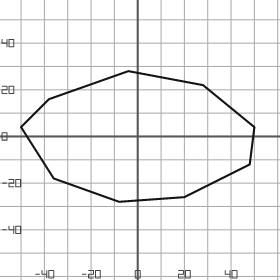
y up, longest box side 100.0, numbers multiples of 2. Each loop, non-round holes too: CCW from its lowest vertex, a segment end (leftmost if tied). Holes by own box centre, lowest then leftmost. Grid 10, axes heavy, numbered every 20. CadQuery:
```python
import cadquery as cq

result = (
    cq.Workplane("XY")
    .moveTo(-8.0, -28.0)
    .lineTo(20.0, -26.0)
    .lineTo(48.0, -12.0)
    .lineTo(50.0, 4.0)
    .lineTo(28.0, 22.0)
    .lineTo(-4.0, 28.0)
    .lineTo(-38.0, 16.0)
    .lineTo(-50.0, 4.0)
    .lineTo(-36.0, -18.0)
    .close()
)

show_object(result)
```